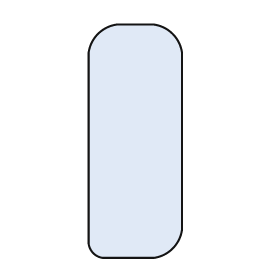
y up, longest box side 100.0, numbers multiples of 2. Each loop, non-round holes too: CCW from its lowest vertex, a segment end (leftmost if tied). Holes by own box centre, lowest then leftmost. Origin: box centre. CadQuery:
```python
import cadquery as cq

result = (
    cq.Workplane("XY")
    .moveTo(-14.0, -50.0)
    .lineTo(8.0, -50.0)
    .threePointArc((16.0, -46.0), (20.0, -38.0))
    .lineTo(20.0, 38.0)
    .threePointArc((16.0, 46.0), (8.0, 50.0))
    .lineTo(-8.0, 50.0)
    .threePointArc((-16.0, 46.0), (-20.0, 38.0))
    .lineTo(-20.0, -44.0)
    .threePointArc((-18.0, -48.0), (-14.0, -50.0))
    .close()
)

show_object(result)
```